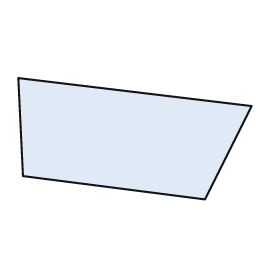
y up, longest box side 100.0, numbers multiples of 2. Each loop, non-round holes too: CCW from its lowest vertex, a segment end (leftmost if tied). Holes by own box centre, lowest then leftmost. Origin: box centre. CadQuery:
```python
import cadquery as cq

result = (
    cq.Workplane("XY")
    .moveTo(30.0, -26.0)
    .lineTo(50.0, 14.0)
    .lineTo(-50.0, 26.0)
    .lineTo(-48.0, -16.0)
    .close()
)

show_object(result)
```